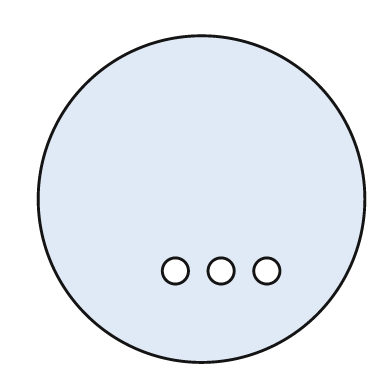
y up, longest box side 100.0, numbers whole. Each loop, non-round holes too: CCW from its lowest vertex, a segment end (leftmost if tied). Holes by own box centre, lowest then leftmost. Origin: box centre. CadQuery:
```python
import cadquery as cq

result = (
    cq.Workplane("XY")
    .moveTo(0.0, 0.0)
    .circle(50.0)
    .moveTo(-8.0, -22.0)
    .circle(4.0)
    .moveTo(6.0, -22.0)
    .circle(4.0)
    .moveTo(20.0, -22.0)
    .circle(4.0)
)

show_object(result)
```